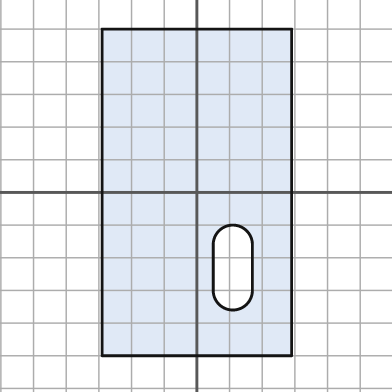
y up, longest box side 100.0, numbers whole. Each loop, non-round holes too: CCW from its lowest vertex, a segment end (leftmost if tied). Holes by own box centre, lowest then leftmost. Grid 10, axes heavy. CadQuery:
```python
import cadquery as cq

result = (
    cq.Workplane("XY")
    .moveTo(-29.0, -50.0)
    .lineTo(29.0, -50.0)
    .lineTo(29.0, 50.0)
    .lineTo(-29.0, 50.0)
    .close()
    .moveTo(5.0, -30.0)
    .threePointArc((11.0, -36.0), (17.0, -30.0))
    .lineTo(17.0, -16.0)
    .threePointArc((11.0, -10.0), (5.0, -16.0))
    .close()
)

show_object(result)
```